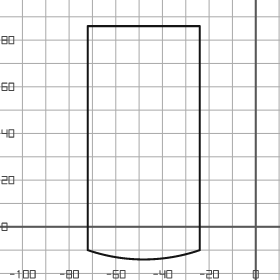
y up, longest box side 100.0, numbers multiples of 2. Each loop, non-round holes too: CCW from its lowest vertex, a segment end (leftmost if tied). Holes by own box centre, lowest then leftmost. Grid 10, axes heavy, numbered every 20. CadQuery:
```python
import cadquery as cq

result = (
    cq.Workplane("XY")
    .moveTo(-72.0, -10.0)
    .threePointArc((-48.0, -14.0), (-24.0, -10.0))
    .lineTo(-24.0, 86.0)
    .lineTo(-72.0, 86.0)
    .close()
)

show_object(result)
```